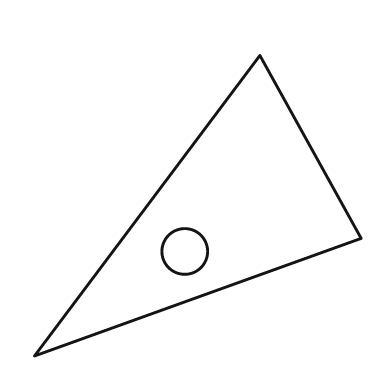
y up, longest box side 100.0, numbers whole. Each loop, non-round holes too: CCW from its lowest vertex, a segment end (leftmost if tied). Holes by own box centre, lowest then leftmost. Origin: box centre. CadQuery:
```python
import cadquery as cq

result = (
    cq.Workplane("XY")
    .moveTo(-50.0, -46.0)
    .lineTo(50.0, -10.0)
    .lineTo(19.0, 46.0)
    .close()
    .moveTo(-4.0, -14.0)
    .circle(7.0)
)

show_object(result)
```